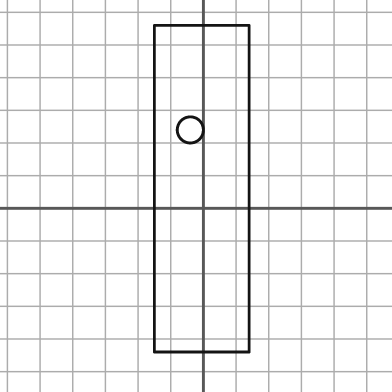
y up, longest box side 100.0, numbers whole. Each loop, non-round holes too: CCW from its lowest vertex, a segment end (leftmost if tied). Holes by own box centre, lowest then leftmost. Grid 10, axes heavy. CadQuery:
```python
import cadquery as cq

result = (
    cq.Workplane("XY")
    .moveTo(-15.0, -44.0)
    .lineTo(14.0, -44.0)
    .lineTo(14.0, 56.0)
    .lineTo(-15.0, 56.0)
    .close()
    .moveTo(-4.0, 24.0)
    .circle(4.0)
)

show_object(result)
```